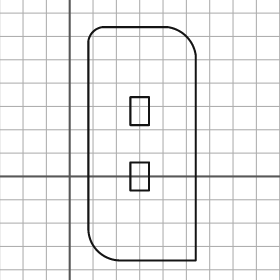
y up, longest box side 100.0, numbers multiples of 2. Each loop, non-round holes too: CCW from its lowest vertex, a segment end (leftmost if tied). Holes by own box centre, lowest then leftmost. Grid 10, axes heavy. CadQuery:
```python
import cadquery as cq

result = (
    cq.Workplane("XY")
    .moveTo(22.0, -36.0)
    .lineTo(54.0, -36.0)
    .lineTo(54.0, 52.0)
    .threePointArc((50.0, 60.0), (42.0, 64.0))
    .lineTo(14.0, 64.0)
    .threePointArc((10.0, 62.0), (8.0, 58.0))
    .lineTo(8.0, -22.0)
    .threePointArc((12.0, -32.0), (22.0, -36.0))
    .close()
    .moveTo(26.0, -6.0)
    .lineTo(34.0, -6.0)
    .lineTo(34.0, 6.0)
    .lineTo(26.0, 6.0)
    .close()
    .moveTo(26.0, 22.0)
    .lineTo(34.0, 22.0)
    .lineTo(34.0, 34.0)
    .lineTo(26.0, 34.0)
    .close()
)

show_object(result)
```